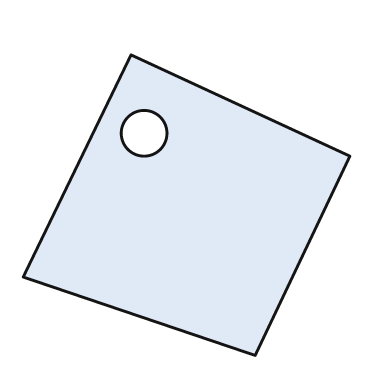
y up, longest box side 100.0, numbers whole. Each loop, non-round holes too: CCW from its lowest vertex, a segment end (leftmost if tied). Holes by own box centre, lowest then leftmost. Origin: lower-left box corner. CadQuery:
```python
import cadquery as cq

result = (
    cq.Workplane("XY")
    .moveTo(71.0, 0.0)
    .lineTo(100.0, 61.0)
    .lineTo(33.0, 92.0)
    .lineTo(0.0, 24.0)
    .close()
    .moveTo(37.0, 68.0)
    .circle(7.0)
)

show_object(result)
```